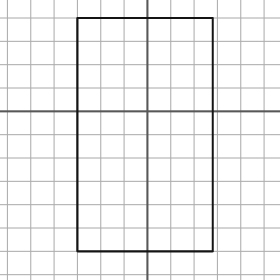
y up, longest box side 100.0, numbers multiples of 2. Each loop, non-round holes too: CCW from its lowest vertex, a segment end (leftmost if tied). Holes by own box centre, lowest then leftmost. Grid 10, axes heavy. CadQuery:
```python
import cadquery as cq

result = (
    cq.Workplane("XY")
    .moveTo(-30.0, -60.0)
    .lineTo(28.0, -60.0)
    .lineTo(28.0, 40.0)
    .lineTo(-30.0, 40.0)
    .close()
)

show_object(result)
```